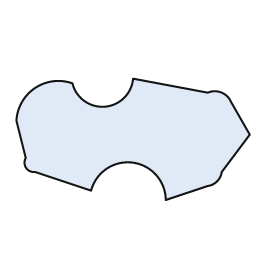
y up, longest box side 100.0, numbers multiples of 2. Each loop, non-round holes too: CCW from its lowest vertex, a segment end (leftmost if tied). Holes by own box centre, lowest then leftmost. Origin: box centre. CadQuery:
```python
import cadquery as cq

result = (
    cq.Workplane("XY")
    .moveTo(14.0, -26.0)
    .lineTo(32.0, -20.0)
    .threePointArc((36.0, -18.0), (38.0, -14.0))
    .lineTo(50.0, 2.0)
    .lineTo(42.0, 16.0)
    .threePointArc((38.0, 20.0), (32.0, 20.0))
    .lineTo(0.0, 26.0)
    .threePointArc((-12.0, 14.0), (-26.0, 24.0))
    .threePointArc((-42.0, 22.0), (-50.0, 8.0))
    .lineTo(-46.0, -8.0)
    .threePointArc((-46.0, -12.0), (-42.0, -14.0))
    .lineTo(-18.0, -22.0)
    .threePointArc((0.0, -10.0), (14.0, -26.0))
    .close()
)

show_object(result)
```